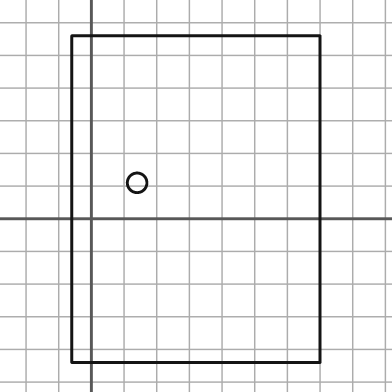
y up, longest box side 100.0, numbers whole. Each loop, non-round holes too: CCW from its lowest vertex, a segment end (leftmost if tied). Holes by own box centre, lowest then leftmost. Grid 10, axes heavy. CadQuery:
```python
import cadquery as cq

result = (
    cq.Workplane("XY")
    .moveTo(-6.0, -44.0)
    .lineTo(70.0, -44.0)
    .lineTo(70.0, 56.0)
    .lineTo(-6.0, 56.0)
    .close()
    .moveTo(14.0, 11.0)
    .circle(3.0)
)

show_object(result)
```